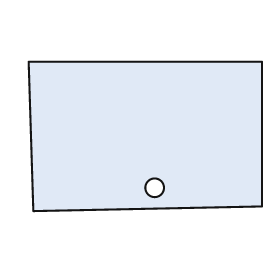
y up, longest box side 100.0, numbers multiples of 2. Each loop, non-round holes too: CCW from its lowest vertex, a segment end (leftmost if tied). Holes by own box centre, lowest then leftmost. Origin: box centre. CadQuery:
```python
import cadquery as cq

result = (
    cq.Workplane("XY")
    .moveTo(-48.0, -32.0)
    .lineTo(50.0, -30.0)
    .lineTo(50.0, 32.0)
    .lineTo(-50.0, 32.0)
    .close()
    .moveTo(4.0, -22.0)
    .circle(4.0)
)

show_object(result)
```